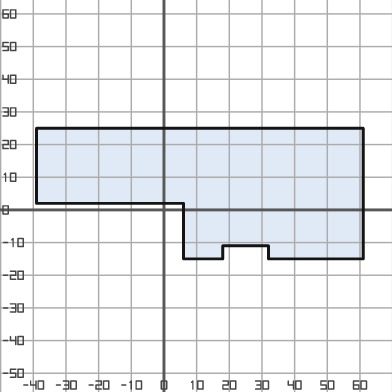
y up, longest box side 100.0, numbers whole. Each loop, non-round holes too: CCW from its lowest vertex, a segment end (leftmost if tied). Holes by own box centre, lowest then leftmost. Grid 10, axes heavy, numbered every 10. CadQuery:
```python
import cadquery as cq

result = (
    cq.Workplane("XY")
    .moveTo(6.0, -15.0)
    .lineTo(18.0, -15.0)
    .lineTo(18.0, -11.0)
    .lineTo(32.0, -11.0)
    .lineTo(32.0, -15.0)
    .lineTo(61.0, -15.0)
    .lineTo(61.0, 25.0)
    .lineTo(-39.0, 25.0)
    .lineTo(-39.0, 2.0)
    .lineTo(6.0, 2.0)
    .close()
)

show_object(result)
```